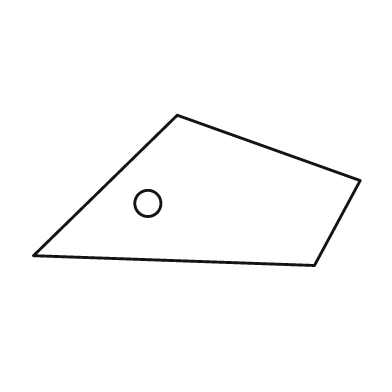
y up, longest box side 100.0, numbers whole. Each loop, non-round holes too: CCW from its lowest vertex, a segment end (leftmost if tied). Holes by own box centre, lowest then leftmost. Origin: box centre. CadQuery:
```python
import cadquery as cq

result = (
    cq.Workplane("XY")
    .moveTo(36.0, -23.0)
    .lineTo(50.0, 3.0)
    .lineTo(-6.0, 23.0)
    .lineTo(-50.0, -20.0)
    .close()
    .moveTo(-15.0, -4.0)
    .circle(4.0)
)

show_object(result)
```